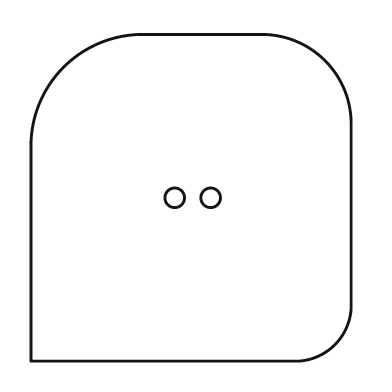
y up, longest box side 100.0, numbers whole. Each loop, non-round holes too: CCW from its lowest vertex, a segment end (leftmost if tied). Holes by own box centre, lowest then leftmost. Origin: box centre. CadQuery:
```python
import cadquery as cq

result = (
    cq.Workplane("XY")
    .moveTo(-49.0, -50.0)
    .lineTo(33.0, -50.0)
    .threePointArc((44.0, -45.0), (49.0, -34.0))
    .lineTo(49.0, 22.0)
    .threePointArc((41.0, 42.0), (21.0, 50.0))
    .lineTo(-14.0, 50.0)
    .threePointArc((-39.0, 40.0), (-49.0, 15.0))
    .close()
    .moveTo(-5.0, 0.0)
    .circle(3.0)
    .moveTo(6.0, 0.0)
    .circle(3.0)
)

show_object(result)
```